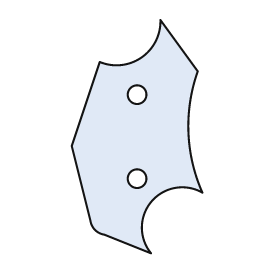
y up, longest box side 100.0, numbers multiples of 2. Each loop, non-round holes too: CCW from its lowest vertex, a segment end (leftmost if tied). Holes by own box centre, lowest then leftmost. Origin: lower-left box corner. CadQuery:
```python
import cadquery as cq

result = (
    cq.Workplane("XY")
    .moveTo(34.0, 0.0)
    .threePointArc((34.0, 22.0), (56.0, 26.0))
    .threePointArc((50.0, 52.0), (54.0, 78.0))
    .lineTo(38.0, 100.0)
    .threePointArc((30.0, 84.0), (12.0, 82.0))
    .lineTo(0.0, 46.0)
    .lineTo(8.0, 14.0)
    .threePointArc((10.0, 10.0), (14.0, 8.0))
    .close()
    .moveTo(28.0, 32.0)
    .circle(4.0)
    .moveTo(28.0, 68.0)
    .circle(4.0)
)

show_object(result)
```